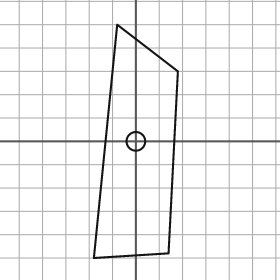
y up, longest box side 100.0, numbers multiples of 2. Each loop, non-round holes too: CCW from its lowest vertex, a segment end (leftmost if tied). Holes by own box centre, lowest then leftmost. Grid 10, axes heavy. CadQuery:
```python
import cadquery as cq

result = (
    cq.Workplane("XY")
    .moveTo(-18.0, -50.0)
    .lineTo(14.0, -48.0)
    .lineTo(18.0, 30.0)
    .lineTo(-8.0, 50.0)
    .close()
    .moveTo(0.0, 0.0)
    .circle(4.0)
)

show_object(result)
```